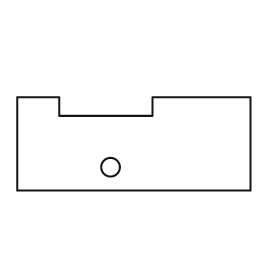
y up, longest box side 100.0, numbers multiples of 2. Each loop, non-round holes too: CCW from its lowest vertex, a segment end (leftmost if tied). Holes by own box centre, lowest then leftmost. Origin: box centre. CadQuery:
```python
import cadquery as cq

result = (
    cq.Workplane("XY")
    .moveTo(-50.0, -20.0)
    .lineTo(50.0, -20.0)
    .lineTo(50.0, 20.0)
    .lineTo(8.0, 20.0)
    .lineTo(8.0, 12.0)
    .lineTo(-32.0, 12.0)
    .lineTo(-32.0, 20.0)
    .lineTo(-50.0, 20.0)
    .close()
    .moveTo(-10.0, -10.0)
    .circle(4.0)
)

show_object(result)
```